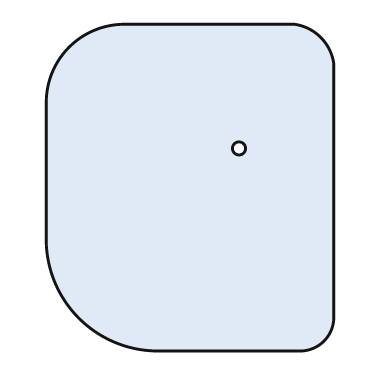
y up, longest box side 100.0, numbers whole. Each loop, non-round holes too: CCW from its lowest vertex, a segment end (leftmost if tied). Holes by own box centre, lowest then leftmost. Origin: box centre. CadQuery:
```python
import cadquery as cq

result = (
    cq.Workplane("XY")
    .moveTo(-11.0, -50.0)
    .lineTo(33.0, -50.0)
    .threePointArc((41.0, -47.0), (44.0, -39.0))
    .lineTo(44.0, 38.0)
    .threePointArc((40.0, 46.0), (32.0, 50.0))
    .lineTo(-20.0, 50.0)
    .threePointArc((-37.0, 43.0), (-44.0, 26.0))
    .lineTo(-44.0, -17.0)
    .threePointArc((-34.0, -40.0), (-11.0, -50.0))
    .close()
    .moveTo(15.0, 12.0)
    .circle(2.0)
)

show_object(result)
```